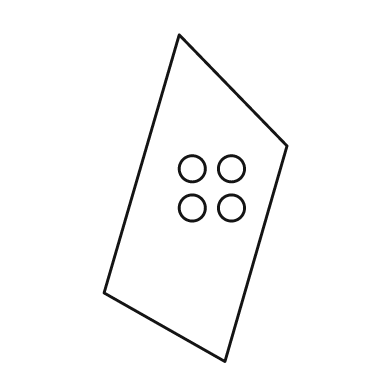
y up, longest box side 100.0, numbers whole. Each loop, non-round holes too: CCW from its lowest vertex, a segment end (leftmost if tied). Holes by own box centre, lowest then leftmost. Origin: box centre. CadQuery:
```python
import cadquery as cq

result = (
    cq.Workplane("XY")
    .moveTo(9.0, -50.0)
    .lineTo(28.0, 16.0)
    .lineTo(-5.0, 50.0)
    .lineTo(-28.0, -29.0)
    .close()
    .moveTo(-1.0, -3.0)
    .circle(4.0)
    .moveTo(11.0, -3.0)
    .circle(4.0)
    .moveTo(-1.0, 9.0)
    .circle(4.0)
    .moveTo(11.0, 9.0)
    .circle(4.0)
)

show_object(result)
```